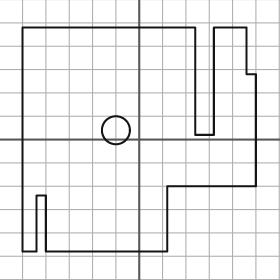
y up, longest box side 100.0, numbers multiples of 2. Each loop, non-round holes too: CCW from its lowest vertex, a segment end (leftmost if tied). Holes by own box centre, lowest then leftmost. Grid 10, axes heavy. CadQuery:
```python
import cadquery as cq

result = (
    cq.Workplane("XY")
    .moveTo(-50.0, -48.0)
    .lineTo(-44.0, -48.0)
    .lineTo(-44.0, -24.0)
    .lineTo(-40.0, -24.0)
    .lineTo(-40.0, -48.0)
    .lineTo(12.0, -48.0)
    .lineTo(12.0, -20.0)
    .lineTo(50.0, -20.0)
    .lineTo(50.0, 28.0)
    .lineTo(46.0, 28.0)
    .lineTo(46.0, 48.0)
    .lineTo(32.0, 48.0)
    .lineTo(32.0, 2.0)
    .lineTo(24.0, 2.0)
    .lineTo(24.0, 48.0)
    .lineTo(-50.0, 48.0)
    .close()
    .moveTo(-10.0, 4.0)
    .circle(6.0)
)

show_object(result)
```